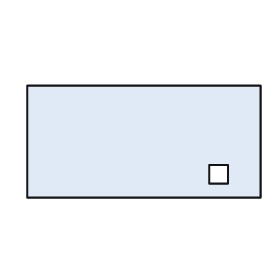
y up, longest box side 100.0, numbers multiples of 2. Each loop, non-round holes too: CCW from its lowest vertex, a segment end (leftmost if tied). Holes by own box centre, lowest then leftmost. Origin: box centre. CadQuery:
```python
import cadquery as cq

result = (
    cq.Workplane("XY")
    .moveTo(-50.0, -24.0)
    .lineTo(50.0, -24.0)
    .lineTo(50.0, 24.0)
    .lineTo(-50.0, 24.0)
    .close()
    .moveTo(28.0, -18.0)
    .lineTo(36.0, -18.0)
    .lineTo(36.0, -10.0)
    .lineTo(28.0, -10.0)
    .close()
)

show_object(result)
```